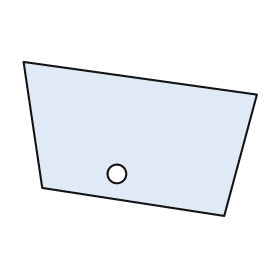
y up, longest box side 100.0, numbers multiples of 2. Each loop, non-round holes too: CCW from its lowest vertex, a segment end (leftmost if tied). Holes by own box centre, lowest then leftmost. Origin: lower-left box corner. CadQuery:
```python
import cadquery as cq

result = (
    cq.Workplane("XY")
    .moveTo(86.0, 0.0)
    .lineTo(100.0, 52.0)
    .lineTo(0.0, 66.0)
    .lineTo(8.0, 12.0)
    .close()
    .moveTo(40.0, 18.0)
    .circle(4.0)
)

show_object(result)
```